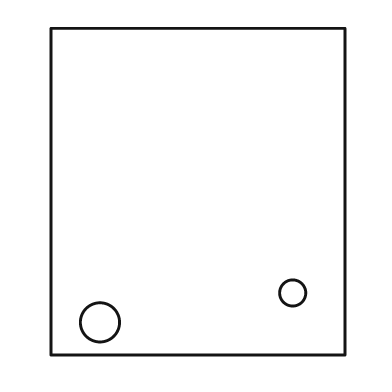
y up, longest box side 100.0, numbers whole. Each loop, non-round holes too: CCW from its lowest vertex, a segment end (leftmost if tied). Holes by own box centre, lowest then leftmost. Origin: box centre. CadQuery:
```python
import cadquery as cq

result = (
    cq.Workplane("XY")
    .moveTo(-45.0, -50.0)
    .lineTo(45.0, -50.0)
    .lineTo(45.0, 50.0)
    .lineTo(-45.0, 50.0)
    .close()
    .moveTo(-30.0, -40.0)
    .circle(6.0)
    .moveTo(29.0, -31.0)
    .circle(4.0)
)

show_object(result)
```